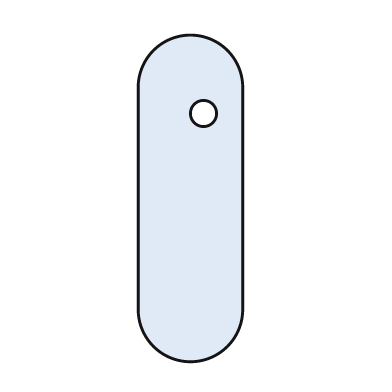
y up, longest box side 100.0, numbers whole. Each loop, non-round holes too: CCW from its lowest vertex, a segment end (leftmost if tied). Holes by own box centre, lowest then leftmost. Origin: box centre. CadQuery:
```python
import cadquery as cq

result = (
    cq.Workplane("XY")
    .moveTo(-16.0, -34.0)
    .threePointArc((0.0, -50.0), (16.0, -34.0))
    .lineTo(16.0, 34.0)
    .threePointArc((0.0, 50.0), (-16.0, 34.0))
    .close()
    .moveTo(4.0, 26.0)
    .circle(4.0)
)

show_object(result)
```